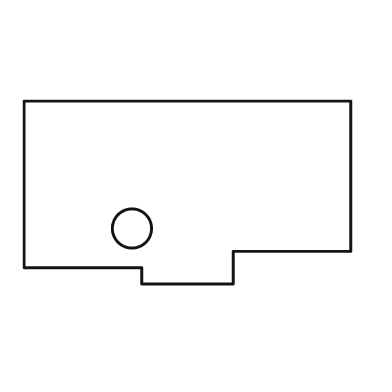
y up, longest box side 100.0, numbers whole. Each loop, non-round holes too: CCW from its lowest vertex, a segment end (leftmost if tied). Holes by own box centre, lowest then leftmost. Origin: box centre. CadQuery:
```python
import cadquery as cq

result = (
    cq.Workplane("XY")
    .moveTo(-14.0, -28.0)
    .lineTo(14.0, -28.0)
    .lineTo(14.0, -18.0)
    .lineTo(50.0, -18.0)
    .lineTo(50.0, 28.0)
    .lineTo(-50.0, 28.0)
    .lineTo(-50.0, -23.0)
    .lineTo(-14.0, -23.0)
    .close()
    .moveTo(-17.0, -11.0)
    .circle(6.0)
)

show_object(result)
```